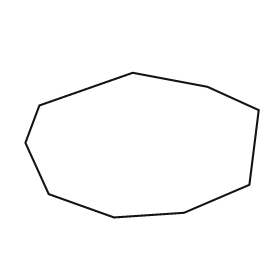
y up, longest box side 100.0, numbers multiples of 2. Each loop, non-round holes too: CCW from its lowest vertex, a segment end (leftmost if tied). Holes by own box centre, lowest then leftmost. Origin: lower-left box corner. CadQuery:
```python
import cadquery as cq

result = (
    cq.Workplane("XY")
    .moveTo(38.0, 0.0)
    .lineTo(68.0, 2.0)
    .lineTo(96.0, 14.0)
    .lineTo(100.0, 46.0)
    .lineTo(78.0, 56.0)
    .lineTo(46.0, 62.0)
    .lineTo(6.0, 48.0)
    .lineTo(0.0, 32.0)
    .lineTo(10.0, 10.0)
    .close()
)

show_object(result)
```